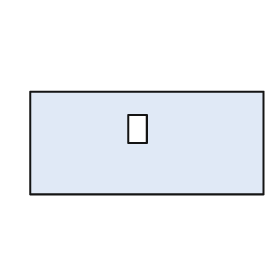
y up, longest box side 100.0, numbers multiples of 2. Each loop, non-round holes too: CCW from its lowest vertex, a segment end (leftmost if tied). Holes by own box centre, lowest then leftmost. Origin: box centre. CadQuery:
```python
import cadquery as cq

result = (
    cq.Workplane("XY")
    .moveTo(-50.0, -22.0)
    .lineTo(50.0, -22.0)
    .lineTo(50.0, 22.0)
    .lineTo(-50.0, 22.0)
    .close()
    .moveTo(-8.0, 0.0)
    .lineTo(0.0, 0.0)
    .lineTo(0.0, 12.0)
    .lineTo(-8.0, 12.0)
    .close()
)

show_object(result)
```